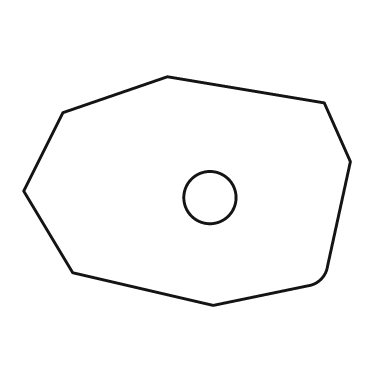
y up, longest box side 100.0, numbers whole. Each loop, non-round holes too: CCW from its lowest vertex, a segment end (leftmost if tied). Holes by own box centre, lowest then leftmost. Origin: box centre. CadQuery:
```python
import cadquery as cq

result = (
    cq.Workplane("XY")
    .moveTo(8.0, -35.0)
    .lineTo(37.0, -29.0)
    .threePointArc((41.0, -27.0), (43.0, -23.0))
    .lineTo(50.0, 9.0)
    .lineTo(42.0, 27.0)
    .lineTo(-6.0, 35.0)
    .lineTo(-38.0, 24.0)
    .lineTo(-50.0, 0.0)
    .lineTo(-35.0, -25.0)
    .close()
    .moveTo(7.0, -2.0)
    .circle(8.0)
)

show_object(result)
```